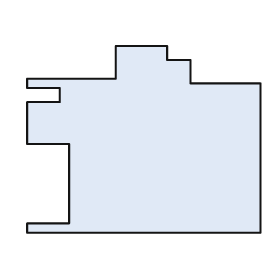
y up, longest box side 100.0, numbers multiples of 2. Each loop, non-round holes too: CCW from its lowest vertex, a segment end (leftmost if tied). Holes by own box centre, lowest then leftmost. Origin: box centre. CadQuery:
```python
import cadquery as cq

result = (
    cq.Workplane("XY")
    .moveTo(-50.0, -40.0)
    .lineTo(50.0, -40.0)
    .lineTo(50.0, 24.0)
    .lineTo(20.0, 24.0)
    .lineTo(20.0, 34.0)
    .lineTo(10.0, 34.0)
    .lineTo(10.0, 40.0)
    .lineTo(-12.0, 40.0)
    .lineTo(-12.0, 26.0)
    .lineTo(-50.0, 26.0)
    .lineTo(-50.0, 22.0)
    .lineTo(-36.0, 22.0)
    .lineTo(-36.0, 16.0)
    .lineTo(-50.0, 16.0)
    .lineTo(-50.0, -2.0)
    .lineTo(-32.0, -2.0)
    .lineTo(-32.0, -36.0)
    .lineTo(-50.0, -36.0)
    .close()
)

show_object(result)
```